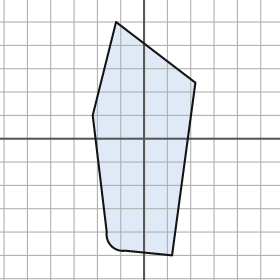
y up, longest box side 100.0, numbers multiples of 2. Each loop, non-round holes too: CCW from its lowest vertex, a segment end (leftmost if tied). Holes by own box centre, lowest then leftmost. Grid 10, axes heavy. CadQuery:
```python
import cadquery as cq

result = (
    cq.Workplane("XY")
    .moveTo(12.0, -50.0)
    .lineTo(22.0, 24.0)
    .lineTo(-12.0, 50.0)
    .lineTo(-22.0, 10.0)
    .lineTo(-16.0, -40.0)
    .threePointArc((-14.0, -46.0), (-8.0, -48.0))
    .close()
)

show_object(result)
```